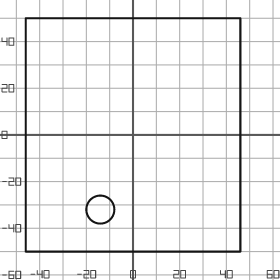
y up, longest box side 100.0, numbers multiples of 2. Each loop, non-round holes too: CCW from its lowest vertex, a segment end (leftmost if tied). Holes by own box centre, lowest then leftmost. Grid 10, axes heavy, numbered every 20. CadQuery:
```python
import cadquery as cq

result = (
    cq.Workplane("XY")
    .moveTo(-46.0, -50.0)
    .lineTo(46.0, -50.0)
    .lineTo(46.0, 50.0)
    .lineTo(-46.0, 50.0)
    .close()
    .moveTo(-14.0, -32.0)
    .circle(6.0)
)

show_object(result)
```